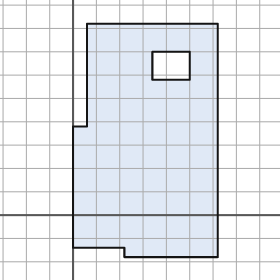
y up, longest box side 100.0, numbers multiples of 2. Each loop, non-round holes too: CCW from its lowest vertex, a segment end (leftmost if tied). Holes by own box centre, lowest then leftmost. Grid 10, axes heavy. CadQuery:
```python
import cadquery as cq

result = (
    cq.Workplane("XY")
    .moveTo(22.0, -18.0)
    .lineTo(62.0, -18.0)
    .lineTo(62.0, 82.0)
    .lineTo(6.0, 82.0)
    .lineTo(6.0, 38.0)
    .lineTo(0.0, 38.0)
    .lineTo(0.0, -14.0)
    .lineTo(22.0, -14.0)
    .close()
    .moveTo(34.0, 58.0)
    .lineTo(50.0, 58.0)
    .lineTo(50.0, 70.0)
    .lineTo(34.0, 70.0)
    .close()
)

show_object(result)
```